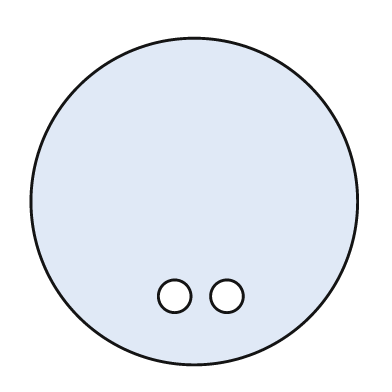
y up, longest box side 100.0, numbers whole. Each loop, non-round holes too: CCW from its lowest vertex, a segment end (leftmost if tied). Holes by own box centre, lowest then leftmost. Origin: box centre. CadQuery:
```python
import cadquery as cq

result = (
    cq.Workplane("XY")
    .moveTo(0.0, 0.0)
    .circle(50.0)
    .moveTo(-6.0, -29.0)
    .circle(5.0)
    .moveTo(10.0, -29.0)
    .circle(5.0)
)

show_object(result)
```